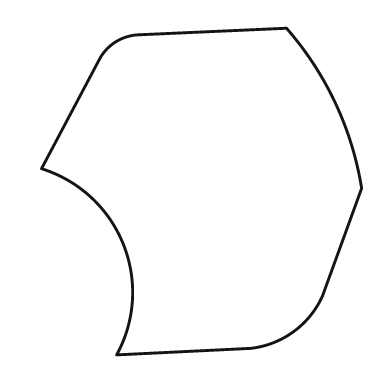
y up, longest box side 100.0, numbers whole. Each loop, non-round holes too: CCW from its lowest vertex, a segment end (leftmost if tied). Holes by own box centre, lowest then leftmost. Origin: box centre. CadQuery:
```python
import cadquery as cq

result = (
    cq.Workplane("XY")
    .moveTo(-26.0, -50.0)
    .lineTo(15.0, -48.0)
    .threePointArc((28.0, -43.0), (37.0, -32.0))
    .lineTo(49.0, 1.0)
    .threePointArc((41.0, 27.0), (26.0, 50.0))
    .lineTo(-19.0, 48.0)
    .threePointArc((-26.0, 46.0), (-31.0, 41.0))
    .lineTo(-49.0, 7.0)
    .threePointArc((-24.0, -16.0), (-26.0, -50.0))
    .close()
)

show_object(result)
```